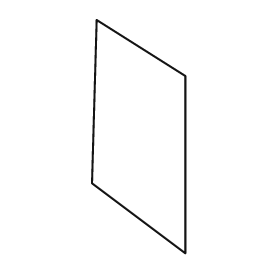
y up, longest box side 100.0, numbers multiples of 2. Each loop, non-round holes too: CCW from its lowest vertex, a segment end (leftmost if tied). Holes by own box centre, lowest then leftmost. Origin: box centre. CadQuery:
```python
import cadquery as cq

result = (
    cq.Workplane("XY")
    .moveTo(20.0, -50.0)
    .lineTo(20.0, 26.0)
    .lineTo(-18.0, 50.0)
    .lineTo(-20.0, -20.0)
    .close()
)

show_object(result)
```